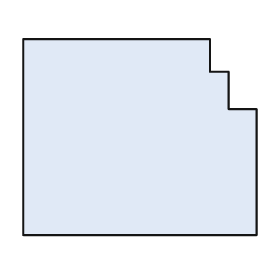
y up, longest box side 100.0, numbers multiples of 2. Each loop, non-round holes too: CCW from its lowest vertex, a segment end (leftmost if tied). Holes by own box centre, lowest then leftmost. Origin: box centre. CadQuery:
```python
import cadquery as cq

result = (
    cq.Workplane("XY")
    .moveTo(-50.0, -42.0)
    .lineTo(50.0, -42.0)
    .lineTo(50.0, 12.0)
    .lineTo(38.0, 12.0)
    .lineTo(38.0, 28.0)
    .lineTo(30.0, 28.0)
    .lineTo(30.0, 42.0)
    .lineTo(-50.0, 42.0)
    .close()
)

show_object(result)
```